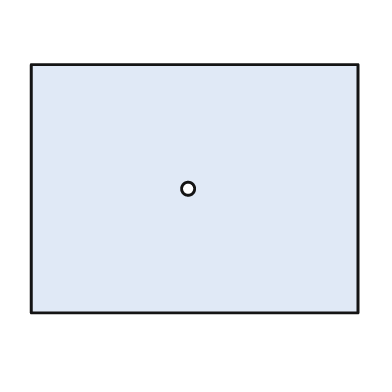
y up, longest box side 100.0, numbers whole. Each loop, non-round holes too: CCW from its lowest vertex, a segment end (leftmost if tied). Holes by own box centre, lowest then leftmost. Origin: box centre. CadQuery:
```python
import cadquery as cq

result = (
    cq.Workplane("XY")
    .moveTo(-50.0, -38.0)
    .lineTo(50.0, -38.0)
    .lineTo(50.0, 38.0)
    .lineTo(-50.0, 38.0)
    .close()
    .moveTo(-2.0, 0.0)
    .circle(2.0)
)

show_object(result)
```